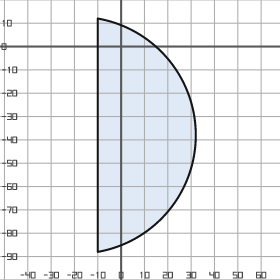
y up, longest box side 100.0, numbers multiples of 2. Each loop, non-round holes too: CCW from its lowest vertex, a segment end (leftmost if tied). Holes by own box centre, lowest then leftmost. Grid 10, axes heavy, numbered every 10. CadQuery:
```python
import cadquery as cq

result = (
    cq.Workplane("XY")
    .moveTo(-10.0, -88.0)
    .threePointArc((32.0, -38.0), (-10.0, 12.0))
    .close()
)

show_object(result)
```